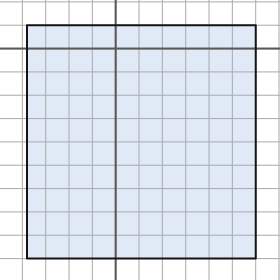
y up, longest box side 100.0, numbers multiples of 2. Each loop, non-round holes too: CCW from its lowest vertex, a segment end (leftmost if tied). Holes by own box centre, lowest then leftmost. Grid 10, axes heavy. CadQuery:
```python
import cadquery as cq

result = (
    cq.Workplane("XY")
    .moveTo(-38.0, -90.0)
    .lineTo(60.0, -90.0)
    .lineTo(60.0, 10.0)
    .lineTo(-38.0, 10.0)
    .close()
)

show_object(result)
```